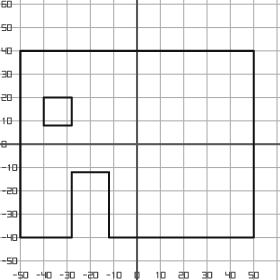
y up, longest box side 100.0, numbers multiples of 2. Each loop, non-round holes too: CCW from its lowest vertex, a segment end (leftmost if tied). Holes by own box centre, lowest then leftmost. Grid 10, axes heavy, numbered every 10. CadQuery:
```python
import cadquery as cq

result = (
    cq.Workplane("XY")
    .moveTo(-50.0, -40.0)
    .lineTo(-28.0, -40.0)
    .lineTo(-28.0, -12.0)
    .lineTo(-12.0, -12.0)
    .lineTo(-12.0, -40.0)
    .lineTo(50.0, -40.0)
    .lineTo(50.0, 40.0)
    .lineTo(-50.0, 40.0)
    .close()
    .moveTo(-40.0, 8.0)
    .lineTo(-28.0, 8.0)
    .lineTo(-28.0, 20.0)
    .lineTo(-40.0, 20.0)
    .close()
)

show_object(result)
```